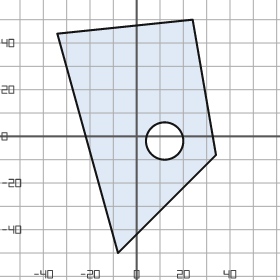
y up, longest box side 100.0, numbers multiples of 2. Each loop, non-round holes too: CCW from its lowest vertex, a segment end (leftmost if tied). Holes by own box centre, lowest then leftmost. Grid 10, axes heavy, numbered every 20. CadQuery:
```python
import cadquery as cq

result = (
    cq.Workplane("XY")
    .moveTo(-8.0, -50.0)
    .lineTo(34.0, -8.0)
    .lineTo(24.0, 50.0)
    .lineTo(-34.0, 44.0)
    .close()
    .moveTo(12.0, -2.0)
    .circle(8.0)
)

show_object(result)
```